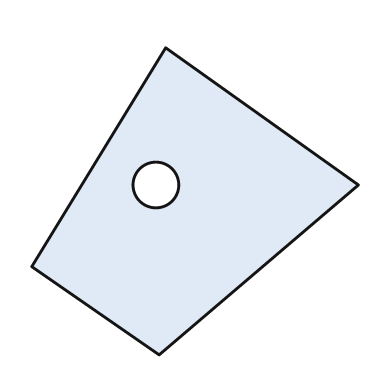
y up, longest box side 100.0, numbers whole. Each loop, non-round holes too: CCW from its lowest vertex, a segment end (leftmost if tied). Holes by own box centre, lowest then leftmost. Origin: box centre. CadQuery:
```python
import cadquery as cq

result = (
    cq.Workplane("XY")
    .moveTo(-11.0, -47.0)
    .lineTo(50.0, 5.0)
    .lineTo(-9.0, 47.0)
    .lineTo(-50.0, -20.0)
    .close()
    .moveTo(-12.0, 5.0)
    .circle(7.0)
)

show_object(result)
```